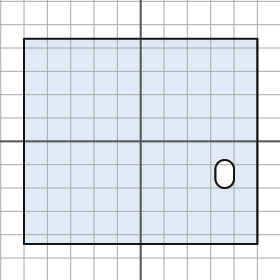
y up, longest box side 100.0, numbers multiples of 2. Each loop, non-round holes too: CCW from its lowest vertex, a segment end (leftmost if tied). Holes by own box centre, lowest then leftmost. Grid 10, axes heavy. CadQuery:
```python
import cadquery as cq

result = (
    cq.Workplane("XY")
    .moveTo(-50.0, -44.0)
    .lineTo(50.0, -44.0)
    .lineTo(50.0, 44.0)
    .lineTo(-50.0, 44.0)
    .close()
    .moveTo(32.0, -16.0)
    .threePointArc((36.0, -20.0), (40.0, -16.0))
    .lineTo(40.0, -12.0)
    .threePointArc((36.0, -8.0), (32.0, -12.0))
    .close()
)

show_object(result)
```